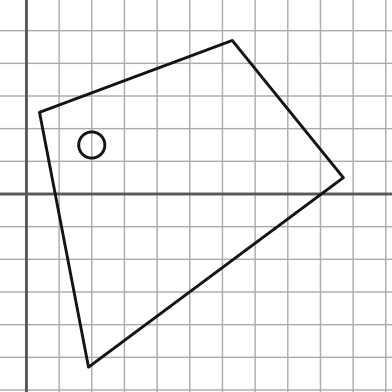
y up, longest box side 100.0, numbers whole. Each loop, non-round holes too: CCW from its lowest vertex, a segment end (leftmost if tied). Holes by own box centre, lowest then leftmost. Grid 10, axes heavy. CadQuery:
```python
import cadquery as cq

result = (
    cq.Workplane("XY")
    .moveTo(19.0, -53.0)
    .lineTo(97.0, 5.0)
    .lineTo(63.0, 47.0)
    .lineTo(4.0, 25.0)
    .close()
    .moveTo(20.0, 15.0)
    .circle(4.0)
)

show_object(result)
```